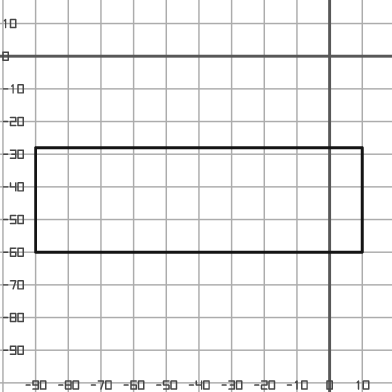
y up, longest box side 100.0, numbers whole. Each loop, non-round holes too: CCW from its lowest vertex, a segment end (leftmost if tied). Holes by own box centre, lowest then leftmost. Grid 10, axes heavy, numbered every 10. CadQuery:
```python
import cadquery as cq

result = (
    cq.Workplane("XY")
    .moveTo(-90.0, -60.0)
    .lineTo(10.0, -60.0)
    .lineTo(10.0, -28.0)
    .lineTo(-90.0, -28.0)
    .close()
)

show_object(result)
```